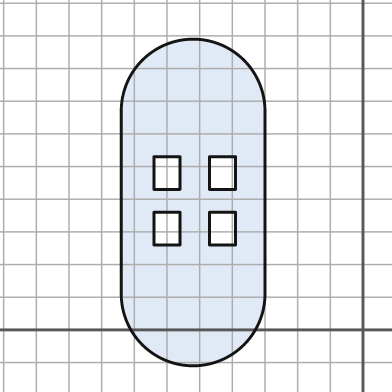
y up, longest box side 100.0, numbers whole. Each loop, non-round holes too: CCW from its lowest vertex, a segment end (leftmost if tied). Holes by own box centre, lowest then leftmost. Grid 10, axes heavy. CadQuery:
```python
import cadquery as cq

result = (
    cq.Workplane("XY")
    .moveTo(-74.0, 11.0)
    .threePointArc((-52.0, -11.0), (-30.0, 11.0))
    .lineTo(-30.0, 67.0)
    .threePointArc((-52.0, 89.0), (-74.0, 67.0))
    .close()
    .moveTo(-64.0, 26.0)
    .lineTo(-56.0, 26.0)
    .lineTo(-56.0, 36.0)
    .lineTo(-64.0, 36.0)
    .close()
    .moveTo(-47.0, 26.0)
    .lineTo(-39.0, 26.0)
    .lineTo(-39.0, 36.0)
    .lineTo(-47.0, 36.0)
    .close()
    .moveTo(-64.0, 43.0)
    .lineTo(-56.0, 43.0)
    .lineTo(-56.0, 53.0)
    .lineTo(-64.0, 53.0)
    .close()
    .moveTo(-47.0, 43.0)
    .lineTo(-39.0, 43.0)
    .lineTo(-39.0, 53.0)
    .lineTo(-47.0, 53.0)
    .close()
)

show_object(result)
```